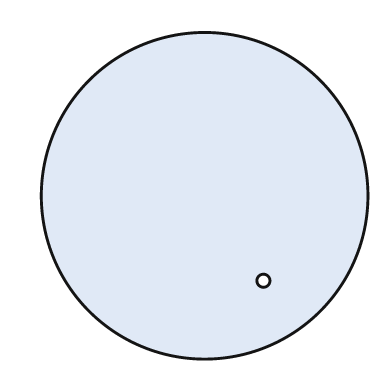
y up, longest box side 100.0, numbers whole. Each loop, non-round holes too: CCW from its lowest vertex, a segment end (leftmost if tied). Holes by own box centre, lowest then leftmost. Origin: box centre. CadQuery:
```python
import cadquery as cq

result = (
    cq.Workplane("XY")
    .moveTo(0.0, 0.0)
    .circle(50.0)
    .moveTo(18.0, -26.0)
    .circle(2.0)
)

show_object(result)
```